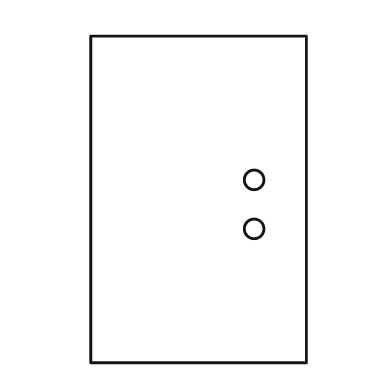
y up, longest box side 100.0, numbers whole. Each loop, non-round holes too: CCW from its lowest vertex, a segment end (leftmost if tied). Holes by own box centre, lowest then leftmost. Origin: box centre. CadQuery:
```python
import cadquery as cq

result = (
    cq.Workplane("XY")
    .moveTo(-33.0, -50.0)
    .lineTo(33.0, -50.0)
    .lineTo(33.0, 50.0)
    .lineTo(-33.0, 50.0)
    .close()
    .moveTo(17.0, -9.0)
    .circle(3.0)
    .moveTo(17.0, 6.0)
    .circle(3.0)
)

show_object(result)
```